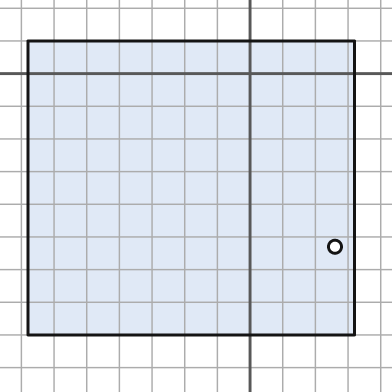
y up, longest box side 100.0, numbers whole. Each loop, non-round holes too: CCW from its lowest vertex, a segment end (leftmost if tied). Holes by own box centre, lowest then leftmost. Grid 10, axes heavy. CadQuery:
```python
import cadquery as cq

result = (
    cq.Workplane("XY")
    .moveTo(-68.0, -80.0)
    .lineTo(32.0, -80.0)
    .lineTo(32.0, 10.0)
    .lineTo(-68.0, 10.0)
    .close()
    .moveTo(26.0, -53.0)
    .circle(2.0)
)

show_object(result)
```